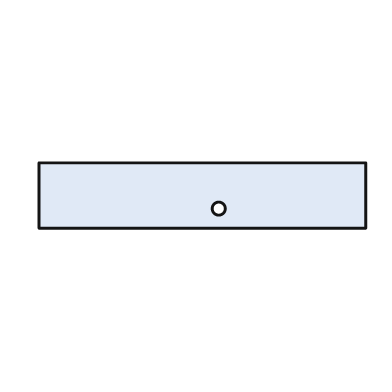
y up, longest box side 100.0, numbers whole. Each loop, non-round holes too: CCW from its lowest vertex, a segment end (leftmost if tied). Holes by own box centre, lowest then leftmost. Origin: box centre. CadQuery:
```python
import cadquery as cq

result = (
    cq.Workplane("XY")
    .moveTo(-50.0, -10.0)
    .lineTo(50.0, -10.0)
    .lineTo(50.0, 10.0)
    .lineTo(-50.0, 10.0)
    .close()
    .moveTo(5.0, -4.0)
    .circle(2.0)
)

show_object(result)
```